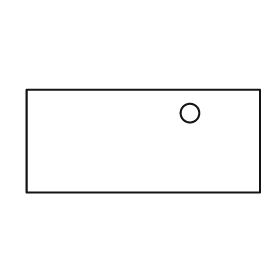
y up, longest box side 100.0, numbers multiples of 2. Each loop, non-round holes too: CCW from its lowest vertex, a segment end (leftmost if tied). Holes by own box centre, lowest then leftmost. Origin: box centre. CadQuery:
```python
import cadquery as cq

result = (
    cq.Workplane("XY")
    .moveTo(-50.0, -22.0)
    .lineTo(50.0, -22.0)
    .lineTo(50.0, 22.0)
    .lineTo(-50.0, 22.0)
    .close()
    .moveTo(20.0, 12.0)
    .circle(4.0)
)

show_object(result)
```